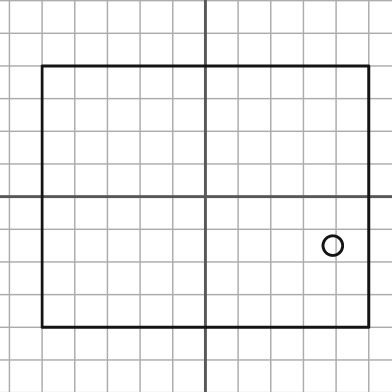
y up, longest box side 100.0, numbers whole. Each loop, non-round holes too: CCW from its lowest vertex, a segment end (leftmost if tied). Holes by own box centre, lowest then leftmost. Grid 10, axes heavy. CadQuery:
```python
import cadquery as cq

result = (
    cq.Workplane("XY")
    .moveTo(-50.0, -40.0)
    .lineTo(50.0, -40.0)
    .lineTo(50.0, 40.0)
    .lineTo(-50.0, 40.0)
    .close()
    .moveTo(39.0, -15.0)
    .circle(3.0)
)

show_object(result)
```